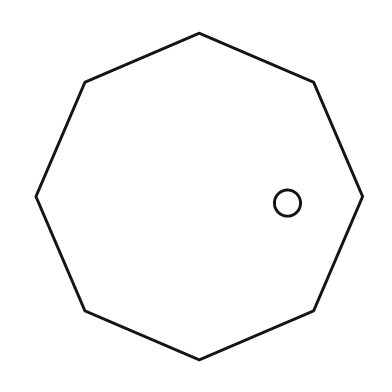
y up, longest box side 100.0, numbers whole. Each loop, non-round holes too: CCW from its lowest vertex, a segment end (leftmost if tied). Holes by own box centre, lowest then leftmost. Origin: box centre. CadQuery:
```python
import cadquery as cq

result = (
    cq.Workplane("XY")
    .moveTo(0.0, -50.0)
    .lineTo(35.0, -35.0)
    .lineTo(50.0, 0.0)
    .lineTo(35.0, 35.0)
    .lineTo(0.0, 50.0)
    .lineTo(-35.0, 35.0)
    .lineTo(-50.0, 0.0)
    .lineTo(-35.0, -35.0)
    .close()
    .moveTo(27.0, -2.0)
    .circle(4.0)
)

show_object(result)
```